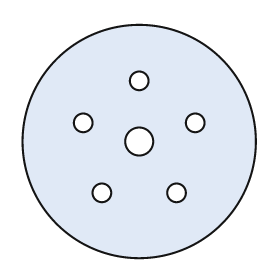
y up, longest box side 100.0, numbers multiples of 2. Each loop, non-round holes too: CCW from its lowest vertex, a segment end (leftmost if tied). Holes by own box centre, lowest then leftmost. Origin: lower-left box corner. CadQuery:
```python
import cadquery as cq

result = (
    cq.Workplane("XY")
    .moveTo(50.0, 50.0)
    .circle(50.0)
    .moveTo(34.0, 28.0)
    .circle(4.0)
    .moveTo(66.0, 28.0)
    .circle(4.0)
    .moveTo(50.0, 50.0)
    .circle(6.0)
    .moveTo(26.0, 58.0)
    .circle(4.0)
    .moveTo(74.0, 58.0)
    .circle(4.0)
    .moveTo(50.0, 76.0)
    .circle(4.0)
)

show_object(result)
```